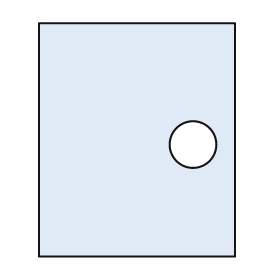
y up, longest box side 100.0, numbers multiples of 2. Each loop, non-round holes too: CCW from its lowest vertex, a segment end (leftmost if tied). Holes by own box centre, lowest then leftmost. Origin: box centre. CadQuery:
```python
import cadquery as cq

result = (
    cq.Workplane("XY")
    .moveTo(-42.0, -50.0)
    .lineTo(42.0, -50.0)
    .lineTo(42.0, 50.0)
    .lineTo(-42.0, 50.0)
    .close()
    .moveTo(24.0, -2.0)
    .circle(10.0)
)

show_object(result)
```